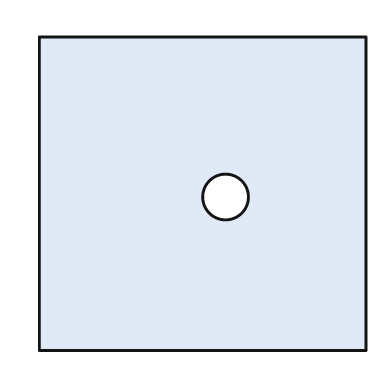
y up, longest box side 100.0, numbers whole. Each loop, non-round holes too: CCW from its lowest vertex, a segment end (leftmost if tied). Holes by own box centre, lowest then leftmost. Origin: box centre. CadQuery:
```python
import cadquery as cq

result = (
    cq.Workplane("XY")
    .moveTo(-50.0, -48.0)
    .lineTo(50.0, -48.0)
    .lineTo(50.0, 48.0)
    .lineTo(-50.0, 48.0)
    .close()
    .moveTo(7.0, -1.0)
    .circle(7.0)
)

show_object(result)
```